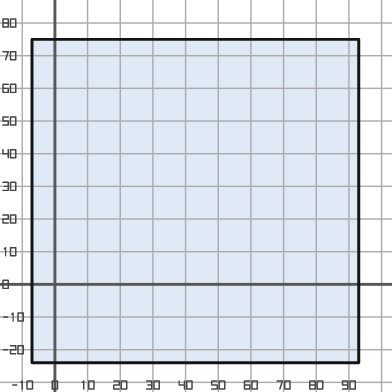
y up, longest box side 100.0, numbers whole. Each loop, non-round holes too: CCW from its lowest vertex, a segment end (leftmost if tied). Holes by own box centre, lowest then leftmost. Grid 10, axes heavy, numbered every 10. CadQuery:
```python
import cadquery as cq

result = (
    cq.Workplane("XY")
    .moveTo(-7.0, -24.0)
    .lineTo(93.0, -24.0)
    .lineTo(93.0, 75.0)
    .lineTo(-7.0, 75.0)
    .close()
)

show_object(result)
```